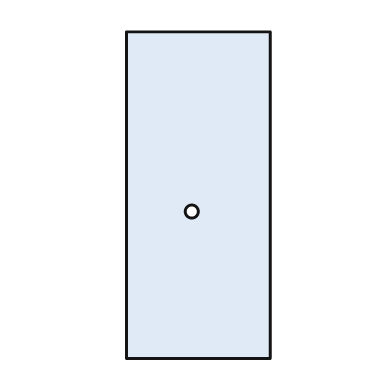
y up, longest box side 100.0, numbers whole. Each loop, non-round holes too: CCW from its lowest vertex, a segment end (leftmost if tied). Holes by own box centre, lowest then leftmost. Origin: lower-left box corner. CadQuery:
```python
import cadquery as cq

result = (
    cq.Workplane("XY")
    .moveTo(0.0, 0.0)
    .lineTo(44.0, 0.0)
    .lineTo(44.0, 100.0)
    .lineTo(0.0, 100.0)
    .close()
    .moveTo(20.0, 45.0)
    .circle(2.0)
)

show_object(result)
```